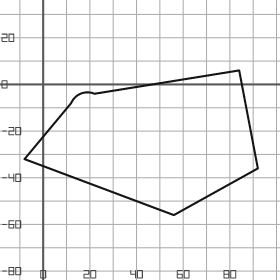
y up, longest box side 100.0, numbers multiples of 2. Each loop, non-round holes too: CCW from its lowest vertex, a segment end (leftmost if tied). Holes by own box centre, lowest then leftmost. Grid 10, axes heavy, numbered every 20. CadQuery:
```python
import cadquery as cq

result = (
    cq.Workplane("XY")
    .moveTo(56.0, -56.0)
    .lineTo(92.0, -36.0)
    .lineTo(84.0, 6.0)
    .lineTo(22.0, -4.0)
    .threePointArc((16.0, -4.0), (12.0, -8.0))
    .lineTo(-8.0, -32.0)
    .close()
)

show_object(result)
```